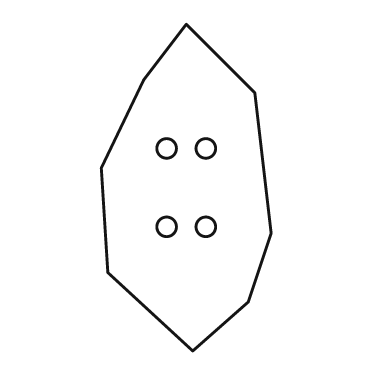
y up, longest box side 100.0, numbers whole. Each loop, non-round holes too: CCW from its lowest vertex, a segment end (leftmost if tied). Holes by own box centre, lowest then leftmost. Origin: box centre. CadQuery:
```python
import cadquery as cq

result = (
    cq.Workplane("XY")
    .moveTo(2.0, -50.0)
    .lineTo(19.0, -35.0)
    .lineTo(26.0, -14.0)
    .lineTo(21.0, 29.0)
    .lineTo(0.0, 50.0)
    .lineTo(-13.0, 33.0)
    .lineTo(-26.0, 6.0)
    .lineTo(-24.0, -26.0)
    .close()
    .moveTo(-6.0, -12.0)
    .circle(3.0)
    .moveTo(6.0, -12.0)
    .circle(3.0)
    .moveTo(-6.0, 12.0)
    .circle(3.0)
    .moveTo(6.0, 12.0)
    .circle(3.0)
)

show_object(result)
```